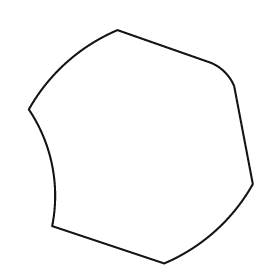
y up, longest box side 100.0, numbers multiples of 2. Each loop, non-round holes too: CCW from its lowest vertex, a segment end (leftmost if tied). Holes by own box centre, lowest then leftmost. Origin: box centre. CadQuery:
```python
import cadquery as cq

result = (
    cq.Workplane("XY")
    .moveTo(10.0, -50.0)
    .threePointArc((32.0, -36.0), (48.0, -16.0))
    .lineTo(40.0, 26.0)
    .threePointArc((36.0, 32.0), (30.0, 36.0))
    .lineTo(-10.0, 50.0)
    .threePointArc((-32.0, 36.0), (-48.0, 16.0))
    .threePointArc((-38.0, -8.0), (-38.0, -34.0))
    .close()
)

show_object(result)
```